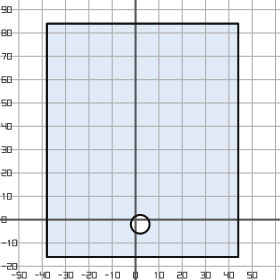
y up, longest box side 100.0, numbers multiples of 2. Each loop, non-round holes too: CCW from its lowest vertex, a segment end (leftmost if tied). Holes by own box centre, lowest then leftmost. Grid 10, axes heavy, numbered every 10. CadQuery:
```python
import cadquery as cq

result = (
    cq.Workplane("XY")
    .moveTo(-38.0, -16.0)
    .lineTo(44.0, -16.0)
    .lineTo(44.0, 84.0)
    .lineTo(-38.0, 84.0)
    .close()
    .moveTo(2.0, -2.0)
    .circle(4.0)
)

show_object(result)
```